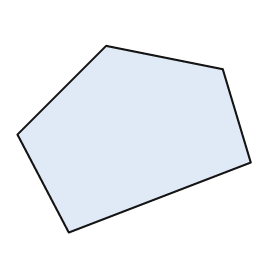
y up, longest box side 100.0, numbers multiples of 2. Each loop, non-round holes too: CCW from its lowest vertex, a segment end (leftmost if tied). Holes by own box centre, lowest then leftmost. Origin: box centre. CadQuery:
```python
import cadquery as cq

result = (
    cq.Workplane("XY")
    .moveTo(-28.0, -40.0)
    .lineTo(50.0, -10.0)
    .lineTo(38.0, 30.0)
    .lineTo(-12.0, 40.0)
    .lineTo(-50.0, 2.0)
    .close()
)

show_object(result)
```